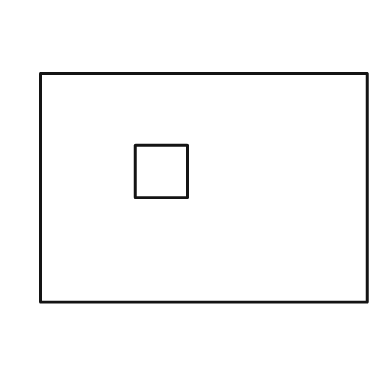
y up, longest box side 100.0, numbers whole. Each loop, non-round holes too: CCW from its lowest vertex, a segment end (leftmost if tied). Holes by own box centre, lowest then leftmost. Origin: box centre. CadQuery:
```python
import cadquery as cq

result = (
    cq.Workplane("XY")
    .moveTo(-50.0, -35.0)
    .lineTo(50.0, -35.0)
    .lineTo(50.0, 35.0)
    .lineTo(-50.0, 35.0)
    .close()
    .moveTo(-21.0, -3.0)
    .lineTo(-5.0, -3.0)
    .lineTo(-5.0, 13.0)
    .lineTo(-21.0, 13.0)
    .close()
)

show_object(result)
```